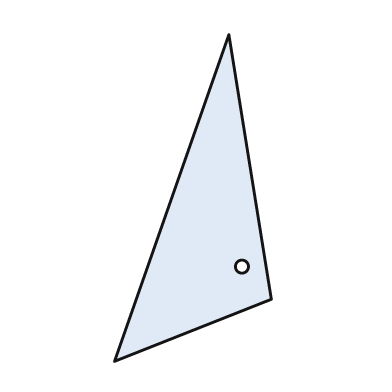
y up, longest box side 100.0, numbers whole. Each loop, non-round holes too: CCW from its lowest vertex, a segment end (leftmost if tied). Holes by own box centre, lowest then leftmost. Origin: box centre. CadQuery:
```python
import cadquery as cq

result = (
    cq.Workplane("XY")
    .moveTo(-24.0, -50.0)
    .lineTo(24.0, -31.0)
    .lineTo(11.0, 50.0)
    .close()
    .moveTo(15.0, -21.0)
    .circle(2.0)
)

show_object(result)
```